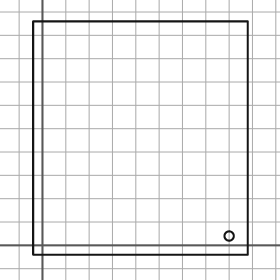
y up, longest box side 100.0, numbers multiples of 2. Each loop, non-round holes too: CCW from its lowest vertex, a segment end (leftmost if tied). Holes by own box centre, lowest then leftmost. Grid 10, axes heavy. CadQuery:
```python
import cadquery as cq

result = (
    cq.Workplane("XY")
    .moveTo(-4.0, -4.0)
    .lineTo(88.0, -4.0)
    .lineTo(88.0, 96.0)
    .lineTo(-4.0, 96.0)
    .close()
    .moveTo(80.0, 4.0)
    .circle(2.0)
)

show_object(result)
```